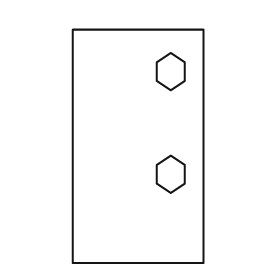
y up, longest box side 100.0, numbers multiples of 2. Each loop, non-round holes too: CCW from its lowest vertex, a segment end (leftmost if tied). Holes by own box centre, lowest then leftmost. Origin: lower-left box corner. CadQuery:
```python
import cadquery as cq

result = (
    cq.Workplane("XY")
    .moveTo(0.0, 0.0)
    .lineTo(56.0, 0.0)
    .lineTo(56.0, 100.0)
    .lineTo(0.0, 100.0)
    .close()
    .moveTo(42.0, 30.0)
    .lineTo(48.0, 34.0)
    .lineTo(48.0, 42.0)
    .lineTo(42.0, 46.0)
    .lineTo(36.0, 42.0)
    .lineTo(36.0, 34.0)
    .close()
    .moveTo(42.0, 74.0)
    .lineTo(48.0, 78.0)
    .lineTo(48.0, 86.0)
    .lineTo(42.0, 90.0)
    .lineTo(36.0, 86.0)
    .lineTo(36.0, 78.0)
    .close()
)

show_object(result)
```